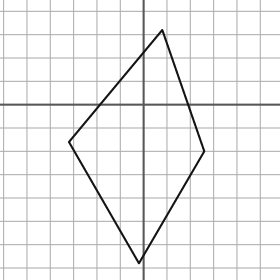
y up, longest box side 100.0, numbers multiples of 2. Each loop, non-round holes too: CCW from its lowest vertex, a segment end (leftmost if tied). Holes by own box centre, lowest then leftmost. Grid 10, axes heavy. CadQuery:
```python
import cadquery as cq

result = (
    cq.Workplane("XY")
    .moveTo(-2.0, -68.0)
    .lineTo(26.0, -20.0)
    .lineTo(8.0, 32.0)
    .lineTo(-32.0, -16.0)
    .close()
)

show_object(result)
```